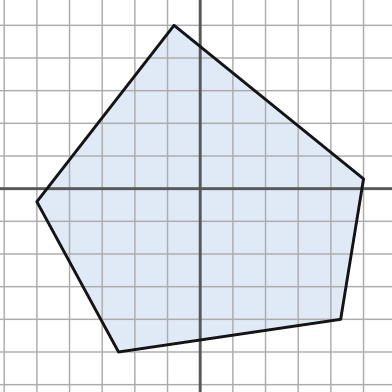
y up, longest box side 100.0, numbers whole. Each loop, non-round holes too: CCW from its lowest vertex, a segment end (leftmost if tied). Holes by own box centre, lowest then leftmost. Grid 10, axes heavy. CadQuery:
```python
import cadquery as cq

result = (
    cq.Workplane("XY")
    .moveTo(-25.0, -50.0)
    .lineTo(43.0, -40.0)
    .lineTo(50.0, 3.0)
    .lineTo(-8.0, 50.0)
    .lineTo(-50.0, -4.0)
    .close()
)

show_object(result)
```